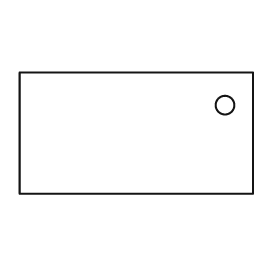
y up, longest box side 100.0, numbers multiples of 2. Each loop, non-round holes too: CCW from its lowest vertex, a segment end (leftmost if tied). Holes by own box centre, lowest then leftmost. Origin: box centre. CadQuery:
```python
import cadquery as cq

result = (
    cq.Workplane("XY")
    .moveTo(-50.0, -26.0)
    .lineTo(50.0, -26.0)
    .lineTo(50.0, 26.0)
    .lineTo(-50.0, 26.0)
    .close()
    .moveTo(38.0, 12.0)
    .circle(4.0)
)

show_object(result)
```